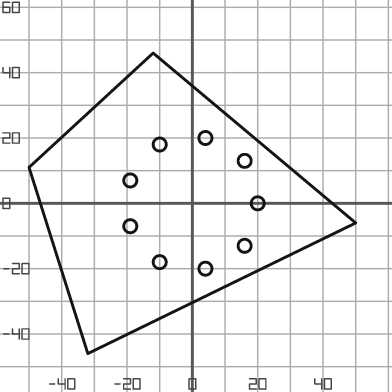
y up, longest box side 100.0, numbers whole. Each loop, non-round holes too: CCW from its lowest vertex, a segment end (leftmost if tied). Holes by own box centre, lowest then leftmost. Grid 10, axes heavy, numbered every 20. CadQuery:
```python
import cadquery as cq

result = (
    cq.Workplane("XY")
    .moveTo(-32.0, -46.0)
    .lineTo(50.0, -6.0)
    .lineTo(-12.0, 46.0)
    .lineTo(-50.0, 11.0)
    .close()
    .moveTo(4.0, -20.0)
    .circle(2.0)
    .moveTo(-10.0, -18.0)
    .circle(2.0)
    .moveTo(16.0, -13.0)
    .circle(2.0)
    .moveTo(-19.0, -7.0)
    .circle(2.0)
    .moveTo(20.0, 0.0)
    .circle(2.0)
    .moveTo(-19.0, 7.0)
    .circle(2.0)
    .moveTo(16.0, 13.0)
    .circle(2.0)
    .moveTo(-10.0, 18.0)
    .circle(2.0)
    .moveTo(4.0, 20.0)
    .circle(2.0)
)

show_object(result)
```